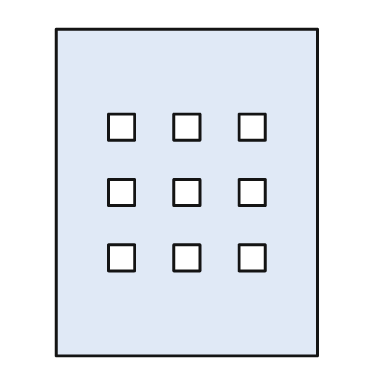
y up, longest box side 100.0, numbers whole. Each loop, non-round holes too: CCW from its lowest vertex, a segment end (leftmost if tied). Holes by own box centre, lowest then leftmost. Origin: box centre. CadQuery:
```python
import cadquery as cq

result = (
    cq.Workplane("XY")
    .moveTo(-40.0, -50.0)
    .lineTo(40.0, -50.0)
    .lineTo(40.0, 50.0)
    .lineTo(-40.0, 50.0)
    .close()
    .moveTo(-24.0, -24.0)
    .lineTo(-16.0, -24.0)
    .lineTo(-16.0, -16.0)
    .lineTo(-24.0, -16.0)
    .close()
    .moveTo(-4.0, -24.0)
    .lineTo(4.0, -24.0)
    .lineTo(4.0, -16.0)
    .lineTo(-4.0, -16.0)
    .close()
    .moveTo(16.0, -24.0)
    .lineTo(24.0, -24.0)
    .lineTo(24.0, -16.0)
    .lineTo(16.0, -16.0)
    .close()
    .moveTo(-24.0, -4.0)
    .lineTo(-16.0, -4.0)
    .lineTo(-16.0, 4.0)
    .lineTo(-24.0, 4.0)
    .close()
    .moveTo(-4.0, -4.0)
    .lineTo(4.0, -4.0)
    .lineTo(4.0, 4.0)
    .lineTo(-4.0, 4.0)
    .close()
    .moveTo(16.0, -4.0)
    .lineTo(24.0, -4.0)
    .lineTo(24.0, 4.0)
    .lineTo(16.0, 4.0)
    .close()
    .moveTo(-24.0, 16.0)
    .lineTo(-16.0, 16.0)
    .lineTo(-16.0, 24.0)
    .lineTo(-24.0, 24.0)
    .close()
    .moveTo(-4.0, 16.0)
    .lineTo(4.0, 16.0)
    .lineTo(4.0, 24.0)
    .lineTo(-4.0, 24.0)
    .close()
    .moveTo(16.0, 16.0)
    .lineTo(24.0, 16.0)
    .lineTo(24.0, 24.0)
    .lineTo(16.0, 24.0)
    .close()
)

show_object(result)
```